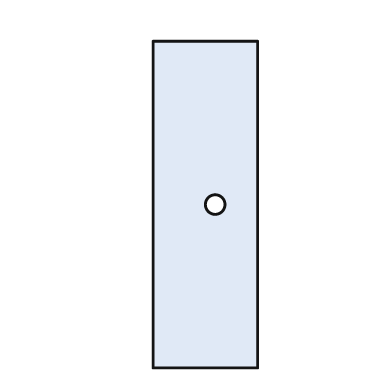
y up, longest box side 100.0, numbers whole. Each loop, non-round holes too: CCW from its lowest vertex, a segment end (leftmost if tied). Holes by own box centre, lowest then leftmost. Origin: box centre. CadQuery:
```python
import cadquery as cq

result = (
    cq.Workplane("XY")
    .moveTo(-16.0, -50.0)
    .lineTo(16.0, -50.0)
    .lineTo(16.0, 50.0)
    .lineTo(-16.0, 50.0)
    .close()
    .moveTo(3.0, 0.0)
    .circle(3.0)
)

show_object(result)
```